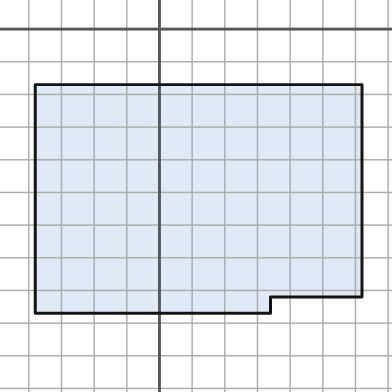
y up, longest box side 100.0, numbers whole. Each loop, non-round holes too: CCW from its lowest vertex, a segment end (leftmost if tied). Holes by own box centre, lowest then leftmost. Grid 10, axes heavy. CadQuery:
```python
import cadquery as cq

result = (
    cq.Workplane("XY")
    .moveTo(-38.0, -87.0)
    .lineTo(34.0, -87.0)
    .lineTo(34.0, -82.0)
    .lineTo(62.0, -82.0)
    .lineTo(62.0, -17.0)
    .lineTo(-38.0, -17.0)
    .close()
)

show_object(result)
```